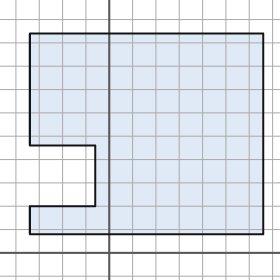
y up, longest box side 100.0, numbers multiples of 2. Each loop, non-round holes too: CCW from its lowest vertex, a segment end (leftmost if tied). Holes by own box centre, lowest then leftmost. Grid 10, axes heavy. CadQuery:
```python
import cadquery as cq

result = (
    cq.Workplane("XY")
    .moveTo(-34.0, 8.0)
    .lineTo(66.0, 8.0)
    .lineTo(66.0, 94.0)
    .lineTo(-34.0, 94.0)
    .lineTo(-34.0, 46.0)
    .lineTo(-6.0, 46.0)
    .lineTo(-6.0, 20.0)
    .lineTo(-34.0, 20.0)
    .close()
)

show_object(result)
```